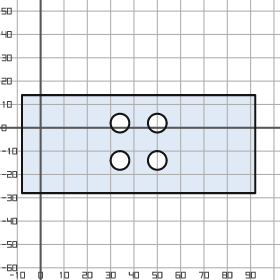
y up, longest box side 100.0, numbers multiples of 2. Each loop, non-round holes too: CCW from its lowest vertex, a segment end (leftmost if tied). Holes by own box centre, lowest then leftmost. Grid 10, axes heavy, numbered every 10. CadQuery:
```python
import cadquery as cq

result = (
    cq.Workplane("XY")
    .moveTo(-8.0, -28.0)
    .lineTo(92.0, -28.0)
    .lineTo(92.0, 14.0)
    .lineTo(-8.0, 14.0)
    .close()
    .moveTo(34.0, -14.0)
    .circle(4.0)
    .moveTo(50.0, -14.0)
    .circle(4.0)
    .moveTo(34.0, 2.0)
    .circle(4.0)
    .moveTo(50.0, 2.0)
    .circle(4.0)
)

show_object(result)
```